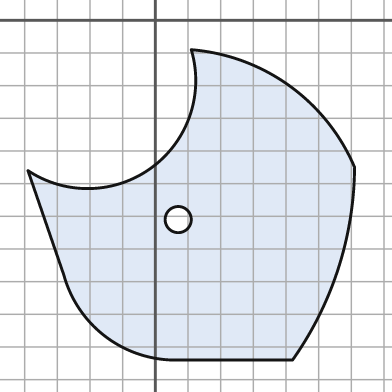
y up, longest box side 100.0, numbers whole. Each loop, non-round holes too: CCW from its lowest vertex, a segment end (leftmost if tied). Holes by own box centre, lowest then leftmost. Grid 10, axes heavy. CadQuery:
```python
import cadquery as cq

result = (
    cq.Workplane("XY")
    .moveTo(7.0, -104.0)
    .lineTo(42.0, -104.0)
    .threePointArc((56.0, -76.0), (61.0, -45.0))
    .threePointArc((41.0, -20.0), (11.0, -9.0))
    .threePointArc((-1.0, -45.0), (-39.0, -46.0))
    .lineTo(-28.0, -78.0)
    .threePointArc((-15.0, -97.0), (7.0, -104.0))
    .close()
    .moveTo(7.0, -61.0)
    .circle(4.0)
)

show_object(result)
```